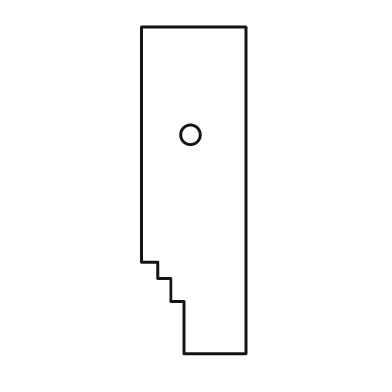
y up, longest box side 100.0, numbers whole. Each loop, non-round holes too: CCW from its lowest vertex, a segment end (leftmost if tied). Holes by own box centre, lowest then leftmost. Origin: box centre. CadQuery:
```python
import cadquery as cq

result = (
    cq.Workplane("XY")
    .moveTo(-3.0, -50.0)
    .lineTo(16.0, -50.0)
    .lineTo(16.0, 50.0)
    .lineTo(-16.0, 50.0)
    .lineTo(-16.0, -22.0)
    .lineTo(-11.0, -22.0)
    .lineTo(-11.0, -27.0)
    .lineTo(-7.0, -27.0)
    .lineTo(-7.0, -34.0)
    .lineTo(-3.0, -34.0)
    .close()
    .moveTo(-1.0, 17.0)
    .circle(3.0)
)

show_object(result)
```